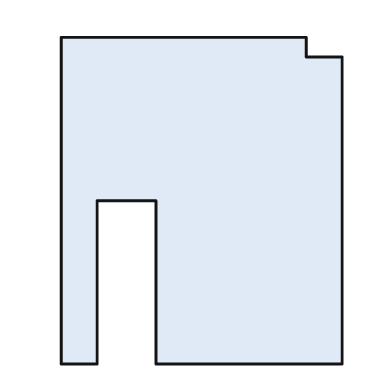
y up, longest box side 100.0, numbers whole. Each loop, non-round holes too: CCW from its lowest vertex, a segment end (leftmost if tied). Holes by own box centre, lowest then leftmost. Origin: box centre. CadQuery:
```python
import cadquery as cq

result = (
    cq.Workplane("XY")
    .moveTo(-43.0, -50.0)
    .lineTo(-32.0, -50.0)
    .lineTo(-32.0, 0.0)
    .lineTo(-14.0, 0.0)
    .lineTo(-14.0, -50.0)
    .lineTo(43.0, -50.0)
    .lineTo(43.0, 44.0)
    .lineTo(32.0, 44.0)
    .lineTo(32.0, 50.0)
    .lineTo(-43.0, 50.0)
    .close()
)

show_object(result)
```